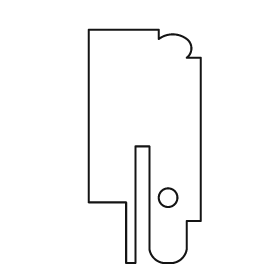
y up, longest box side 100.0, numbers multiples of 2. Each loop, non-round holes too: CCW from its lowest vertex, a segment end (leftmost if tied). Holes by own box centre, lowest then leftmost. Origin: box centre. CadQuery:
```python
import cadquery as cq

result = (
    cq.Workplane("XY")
    .moveTo(-8.0, -50.0)
    .lineTo(-4.0, -50.0)
    .lineTo(-4.0, 0.0)
    .lineTo(2.0, 0.0)
    .lineTo(2.0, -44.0)
    .threePointArc((4.0, -48.0), (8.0, -50.0))
    .lineTo(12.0, -50.0)
    .threePointArc((16.0, -48.0), (18.0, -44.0))
    .lineTo(18.0, -32.0)
    .lineTo(24.0, -32.0)
    .lineTo(24.0, 38.0)
    .lineTo(18.0, 38.0)
    .threePointArc((20.0, 42.0), (18.0, 46.0))
    .threePointArc((12.0, 48.0), (6.0, 46.0))
    .lineTo(6.0, 50.0)
    .lineTo(-24.0, 50.0)
    .lineTo(-24.0, -24.0)
    .lineTo(-8.0, -24.0)
    .close()
    .moveTo(10.0, -22.0)
    .circle(4.0)
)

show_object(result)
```